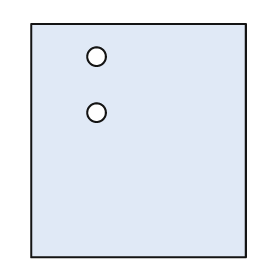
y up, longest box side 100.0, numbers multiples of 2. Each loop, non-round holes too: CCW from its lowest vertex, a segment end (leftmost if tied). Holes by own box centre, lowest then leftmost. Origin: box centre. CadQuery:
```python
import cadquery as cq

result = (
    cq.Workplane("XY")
    .moveTo(-46.0, -50.0)
    .lineTo(46.0, -50.0)
    .lineTo(46.0, 50.0)
    .lineTo(-46.0, 50.0)
    .close()
    .moveTo(-18.0, 12.0)
    .circle(4.0)
    .moveTo(-18.0, 36.0)
    .circle(4.0)
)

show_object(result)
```